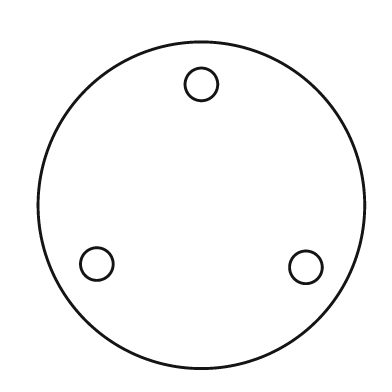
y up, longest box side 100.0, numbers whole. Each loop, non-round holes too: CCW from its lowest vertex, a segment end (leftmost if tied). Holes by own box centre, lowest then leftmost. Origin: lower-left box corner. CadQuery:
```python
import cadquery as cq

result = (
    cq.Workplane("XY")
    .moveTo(50.0, 50.0)
    .circle(50.0)
    .moveTo(82.0, 31.0)
    .circle(5.0)
    .moveTo(18.0, 32.0)
    .circle(5.0)
    .moveTo(50.0, 87.0)
    .circle(5.0)
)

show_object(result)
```